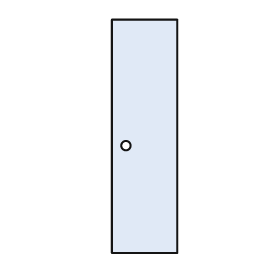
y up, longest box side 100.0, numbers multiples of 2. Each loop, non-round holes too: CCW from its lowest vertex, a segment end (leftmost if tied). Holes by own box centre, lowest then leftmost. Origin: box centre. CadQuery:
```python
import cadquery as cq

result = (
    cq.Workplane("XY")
    .moveTo(-14.0, -50.0)
    .lineTo(14.0, -50.0)
    .lineTo(14.0, 50.0)
    .lineTo(-14.0, 50.0)
    .close()
    .moveTo(-8.0, -4.0)
    .circle(2.0)
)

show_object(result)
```